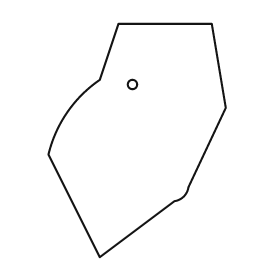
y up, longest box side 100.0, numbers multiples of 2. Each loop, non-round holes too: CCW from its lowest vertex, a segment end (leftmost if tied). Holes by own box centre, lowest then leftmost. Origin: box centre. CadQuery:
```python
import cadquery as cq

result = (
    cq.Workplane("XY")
    .moveTo(-16.0, -50.0)
    .lineTo(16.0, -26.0)
    .threePointArc((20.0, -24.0), (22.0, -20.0))
    .lineTo(38.0, 14.0)
    .lineTo(32.0, 50.0)
    .lineTo(-8.0, 50.0)
    .lineTo(-16.0, 26.0)
    .threePointArc((-30.0, 12.0), (-38.0, -6.0))
    .close()
    .moveTo(-2.0, 24.0)
    .circle(2.0)
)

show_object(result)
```